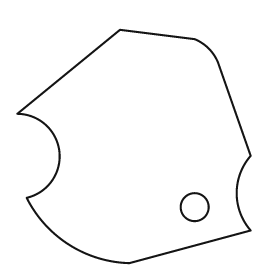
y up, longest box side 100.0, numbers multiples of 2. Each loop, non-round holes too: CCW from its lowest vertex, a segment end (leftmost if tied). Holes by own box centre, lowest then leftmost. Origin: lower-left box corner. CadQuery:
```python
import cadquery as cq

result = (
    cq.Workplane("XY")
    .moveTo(48.0, 0.0)
    .lineTo(100.0, 14.0)
    .threePointArc((94.0, 30.0), (100.0, 46.0))
    .lineTo(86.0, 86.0)
    .threePointArc((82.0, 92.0), (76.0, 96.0))
    .lineTo(44.0, 100.0)
    .lineTo(0.0, 64.0)
    .threePointArc((18.0, 48.0), (4.0, 28.0))
    .threePointArc((22.0, 8.0), (48.0, 0.0))
    .close()
    .moveTo(76.0, 24.0)
    .circle(6.0)
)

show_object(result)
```